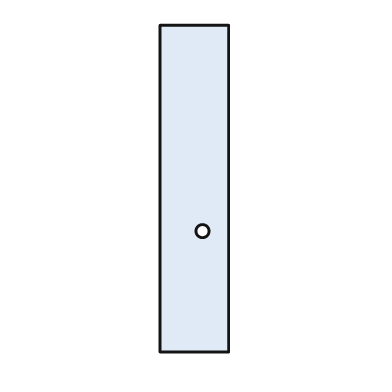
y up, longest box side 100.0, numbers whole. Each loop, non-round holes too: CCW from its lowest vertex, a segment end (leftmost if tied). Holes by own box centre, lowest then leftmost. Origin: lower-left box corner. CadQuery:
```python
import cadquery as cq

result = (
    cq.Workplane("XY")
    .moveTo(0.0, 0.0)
    .lineTo(21.0, 0.0)
    .lineTo(21.0, 100.0)
    .lineTo(0.0, 100.0)
    .close()
    .moveTo(13.0, 37.0)
    .circle(2.0)
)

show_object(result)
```